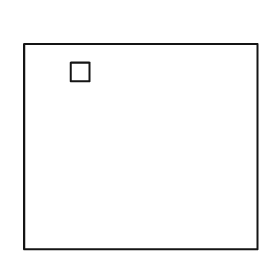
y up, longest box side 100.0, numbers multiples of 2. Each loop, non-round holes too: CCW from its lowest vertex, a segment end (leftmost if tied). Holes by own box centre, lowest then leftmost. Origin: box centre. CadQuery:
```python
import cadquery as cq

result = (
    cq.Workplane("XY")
    .moveTo(-50.0, -44.0)
    .lineTo(50.0, -44.0)
    .lineTo(50.0, 44.0)
    .lineTo(-50.0, 44.0)
    .close()
    .moveTo(-30.0, 28.0)
    .lineTo(-22.0, 28.0)
    .lineTo(-22.0, 36.0)
    .lineTo(-30.0, 36.0)
    .close()
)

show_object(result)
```